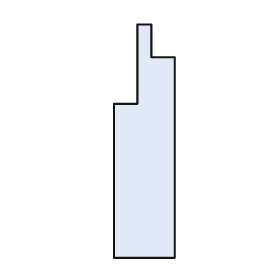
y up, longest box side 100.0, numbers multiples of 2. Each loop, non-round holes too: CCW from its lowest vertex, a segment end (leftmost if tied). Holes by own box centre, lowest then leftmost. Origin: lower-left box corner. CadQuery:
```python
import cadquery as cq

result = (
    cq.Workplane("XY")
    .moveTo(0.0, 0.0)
    .lineTo(26.0, 0.0)
    .lineTo(26.0, 86.0)
    .lineTo(16.0, 86.0)
    .lineTo(16.0, 100.0)
    .lineTo(10.0, 100.0)
    .lineTo(10.0, 66.0)
    .lineTo(0.0, 66.0)
    .close()
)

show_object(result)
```